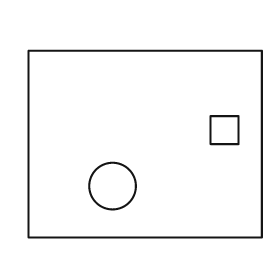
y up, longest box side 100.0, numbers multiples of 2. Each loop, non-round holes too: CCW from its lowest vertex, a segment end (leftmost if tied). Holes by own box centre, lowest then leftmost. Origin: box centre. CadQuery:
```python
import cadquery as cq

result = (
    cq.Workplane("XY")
    .moveTo(-50.0, -40.0)
    .lineTo(50.0, -40.0)
    .lineTo(50.0, 40.0)
    .lineTo(-50.0, 40.0)
    .close()
    .moveTo(-14.0, -18.0)
    .circle(10.0)
    .moveTo(28.0, 0.0)
    .lineTo(40.0, 0.0)
    .lineTo(40.0, 12.0)
    .lineTo(28.0, 12.0)
    .close()
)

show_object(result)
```